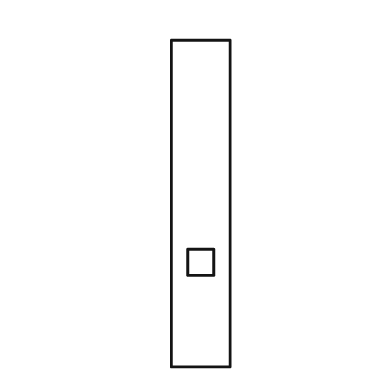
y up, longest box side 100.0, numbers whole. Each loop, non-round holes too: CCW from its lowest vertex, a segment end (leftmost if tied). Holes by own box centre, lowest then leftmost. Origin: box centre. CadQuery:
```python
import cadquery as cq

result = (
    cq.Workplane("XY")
    .moveTo(-9.0, -50.0)
    .lineTo(9.0, -50.0)
    .lineTo(9.0, 50.0)
    .lineTo(-9.0, 50.0)
    .close()
    .moveTo(-4.0, -22.0)
    .lineTo(4.0, -22.0)
    .lineTo(4.0, -14.0)
    .lineTo(-4.0, -14.0)
    .close()
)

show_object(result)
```